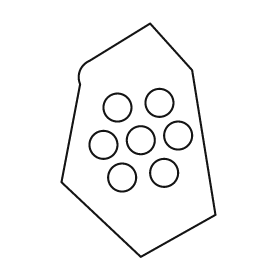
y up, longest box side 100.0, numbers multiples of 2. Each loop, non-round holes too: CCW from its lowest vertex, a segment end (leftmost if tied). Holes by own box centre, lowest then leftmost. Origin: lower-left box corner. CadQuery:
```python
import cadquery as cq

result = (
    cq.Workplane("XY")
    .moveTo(34.0, 0.0)
    .lineTo(66.0, 18.0)
    .lineTo(56.0, 80.0)
    .lineTo(38.0, 100.0)
    .lineTo(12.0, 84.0)
    .threePointArc((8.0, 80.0), (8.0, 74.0))
    .lineTo(0.0, 32.0)
    .close()
    .moveTo(26.0, 34.0)
    .circle(6.0)
    .moveTo(44.0, 36.0)
    .circle(6.0)
    .moveTo(18.0, 48.0)
    .circle(6.0)
    .moveTo(34.0, 50.0)
    .circle(6.0)
    .moveTo(50.0, 52.0)
    .circle(6.0)
    .moveTo(24.0, 64.0)
    .circle(6.0)
    .moveTo(42.0, 66.0)
    .circle(6.0)
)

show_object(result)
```